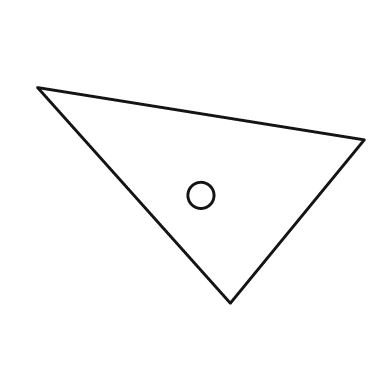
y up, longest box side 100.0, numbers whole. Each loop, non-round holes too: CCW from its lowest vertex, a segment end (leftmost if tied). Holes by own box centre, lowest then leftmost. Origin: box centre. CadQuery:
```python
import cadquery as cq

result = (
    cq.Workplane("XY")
    .moveTo(9.0, -33.0)
    .lineTo(50.0, 17.0)
    .lineTo(-50.0, 33.0)
    .close()
    .moveTo(0.0, 0.0)
    .circle(4.0)
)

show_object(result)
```